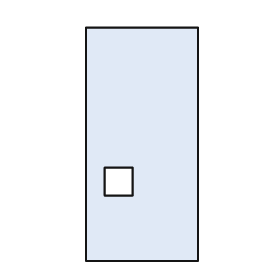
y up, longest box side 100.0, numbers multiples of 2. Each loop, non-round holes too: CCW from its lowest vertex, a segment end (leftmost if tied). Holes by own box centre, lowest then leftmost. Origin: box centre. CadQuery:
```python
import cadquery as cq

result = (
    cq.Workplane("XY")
    .moveTo(-24.0, -50.0)
    .lineTo(24.0, -50.0)
    .lineTo(24.0, 50.0)
    .lineTo(-24.0, 50.0)
    .close()
    .moveTo(-16.0, -22.0)
    .lineTo(-4.0, -22.0)
    .lineTo(-4.0, -10.0)
    .lineTo(-16.0, -10.0)
    .close()
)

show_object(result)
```